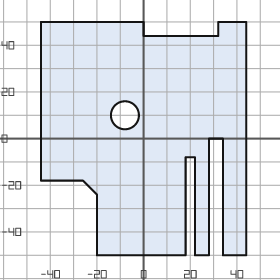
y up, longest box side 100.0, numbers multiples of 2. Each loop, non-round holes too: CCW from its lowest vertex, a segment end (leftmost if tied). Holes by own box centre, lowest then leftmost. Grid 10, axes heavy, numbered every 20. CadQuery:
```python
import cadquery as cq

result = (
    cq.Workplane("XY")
    .moveTo(-20.0, -50.0)
    .lineTo(18.0, -50.0)
    .lineTo(18.0, -8.0)
    .lineTo(22.0, -8.0)
    .lineTo(22.0, -50.0)
    .lineTo(28.0, -50.0)
    .lineTo(28.0, 0.0)
    .lineTo(34.0, 0.0)
    .lineTo(34.0, -50.0)
    .lineTo(44.0, -50.0)
    .lineTo(44.0, 50.0)
    .lineTo(32.0, 50.0)
    .lineTo(32.0, 44.0)
    .lineTo(0.0, 44.0)
    .lineTo(0.0, 50.0)
    .lineTo(-44.0, 50.0)
    .lineTo(-44.0, -18.0)
    .lineTo(-26.0, -18.0)
    .lineTo(-20.0, -24.0)
    .close()
    .moveTo(-8.0, 10.0)
    .circle(6.0)
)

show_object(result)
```